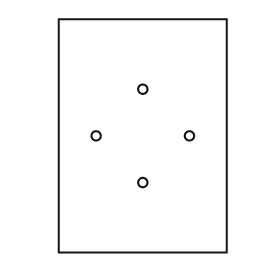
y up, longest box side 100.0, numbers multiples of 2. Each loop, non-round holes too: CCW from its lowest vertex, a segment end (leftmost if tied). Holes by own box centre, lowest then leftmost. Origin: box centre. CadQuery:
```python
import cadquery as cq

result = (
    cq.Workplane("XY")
    .moveTo(-36.0, -50.0)
    .lineTo(36.0, -50.0)
    .lineTo(36.0, 50.0)
    .lineTo(-36.0, 50.0)
    .close()
    .moveTo(0.0, -20.0)
    .circle(2.0)
    .moveTo(-20.0, 0.0)
    .circle(2.0)
    .moveTo(20.0, 0.0)
    .circle(2.0)
    .moveTo(0.0, 20.0)
    .circle(2.0)
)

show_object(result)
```